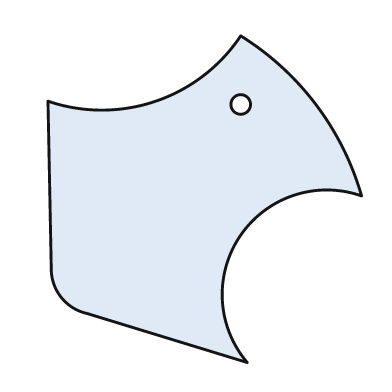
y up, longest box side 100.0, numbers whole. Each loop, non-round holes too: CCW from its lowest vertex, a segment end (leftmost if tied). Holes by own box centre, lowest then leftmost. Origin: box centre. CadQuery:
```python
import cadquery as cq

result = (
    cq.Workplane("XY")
    .moveTo(13.0, -50.0)
    .threePointArc((11.0, -11.0), (48.0, 1.0))
    .threePointArc((34.0, 29.0), (11.0, 50.0))
    .threePointArc((-15.0, 30.0), (-48.0, 30.0))
    .lineTo(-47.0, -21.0)
    .threePointArc((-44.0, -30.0), (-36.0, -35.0))
    .close()
    .moveTo(11.0, 29.0)
    .circle(3.0)
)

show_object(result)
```